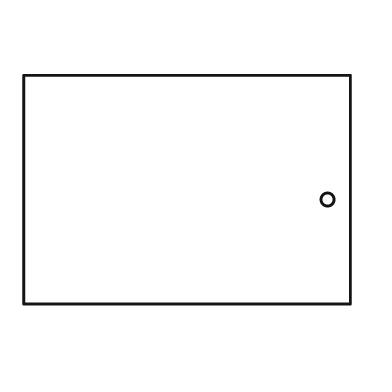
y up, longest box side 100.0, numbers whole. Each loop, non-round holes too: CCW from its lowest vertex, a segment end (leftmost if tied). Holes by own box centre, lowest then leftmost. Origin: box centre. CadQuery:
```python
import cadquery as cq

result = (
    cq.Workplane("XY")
    .moveTo(-50.0, -35.0)
    .lineTo(50.0, -35.0)
    .lineTo(50.0, 35.0)
    .lineTo(-50.0, 35.0)
    .close()
    .moveTo(43.0, -3.0)
    .circle(2.0)
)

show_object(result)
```